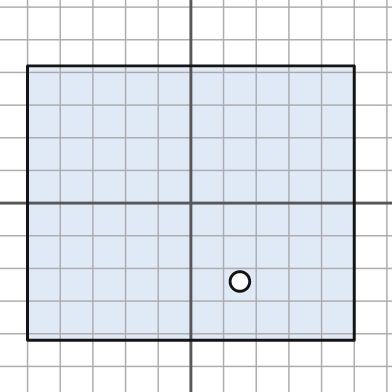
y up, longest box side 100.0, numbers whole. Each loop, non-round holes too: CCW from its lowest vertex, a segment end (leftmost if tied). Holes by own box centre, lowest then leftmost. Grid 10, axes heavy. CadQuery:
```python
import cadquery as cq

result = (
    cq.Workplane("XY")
    .moveTo(-50.0, -42.0)
    .lineTo(50.0, -42.0)
    .lineTo(50.0, 42.0)
    .lineTo(-50.0, 42.0)
    .close()
    .moveTo(15.0, -24.0)
    .circle(3.0)
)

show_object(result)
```